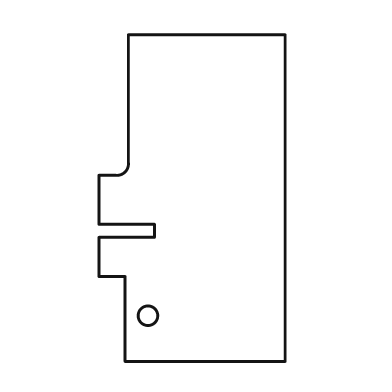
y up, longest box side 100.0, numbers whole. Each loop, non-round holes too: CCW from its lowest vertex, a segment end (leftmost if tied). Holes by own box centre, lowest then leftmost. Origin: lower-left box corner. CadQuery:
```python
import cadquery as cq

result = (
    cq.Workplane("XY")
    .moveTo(8.0, 0.0)
    .lineTo(57.0, 0.0)
    .lineTo(57.0, 100.0)
    .lineTo(9.0, 100.0)
    .lineTo(9.0, 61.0)
    .threePointArc((8.0, 58.0), (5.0, 57.0))
    .lineTo(0.0, 57.0)
    .lineTo(0.0, 42.0)
    .lineTo(17.0, 42.0)
    .lineTo(17.0, 38.0)
    .lineTo(0.0, 38.0)
    .lineTo(0.0, 26.0)
    .lineTo(8.0, 26.0)
    .close()
    .moveTo(15.0, 14.0)
    .circle(3.0)
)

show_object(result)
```